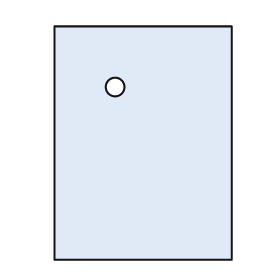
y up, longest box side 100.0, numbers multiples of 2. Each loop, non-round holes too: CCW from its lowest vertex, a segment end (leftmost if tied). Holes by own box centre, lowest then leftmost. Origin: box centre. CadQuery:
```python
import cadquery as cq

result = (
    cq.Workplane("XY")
    .moveTo(-38.0, -50.0)
    .lineTo(38.0, -50.0)
    .lineTo(38.0, 50.0)
    .lineTo(-38.0, 50.0)
    .close()
    .moveTo(-12.0, 24.0)
    .circle(4.0)
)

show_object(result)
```